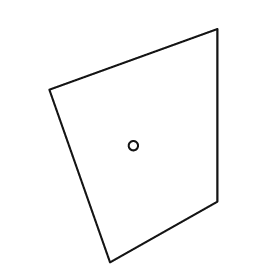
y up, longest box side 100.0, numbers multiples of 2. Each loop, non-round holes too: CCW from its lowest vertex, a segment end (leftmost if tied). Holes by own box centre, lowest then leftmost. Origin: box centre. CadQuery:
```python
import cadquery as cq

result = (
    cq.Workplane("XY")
    .moveTo(-10.0, -50.0)
    .lineTo(36.0, -24.0)
    .lineTo(36.0, 50.0)
    .lineTo(-36.0, 24.0)
    .close()
    .moveTo(0.0, 0.0)
    .circle(2.0)
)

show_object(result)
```